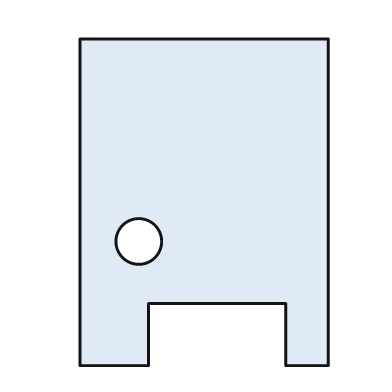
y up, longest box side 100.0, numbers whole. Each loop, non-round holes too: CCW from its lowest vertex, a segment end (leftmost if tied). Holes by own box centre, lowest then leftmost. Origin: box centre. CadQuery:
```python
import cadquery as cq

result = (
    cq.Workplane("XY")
    .moveTo(-38.0, -50.0)
    .lineTo(-17.0, -50.0)
    .lineTo(-17.0, -31.0)
    .lineTo(25.0, -31.0)
    .lineTo(25.0, -50.0)
    .lineTo(38.0, -50.0)
    .lineTo(38.0, 50.0)
    .lineTo(-38.0, 50.0)
    .close()
    .moveTo(-20.0, -12.0)
    .circle(7.0)
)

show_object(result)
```